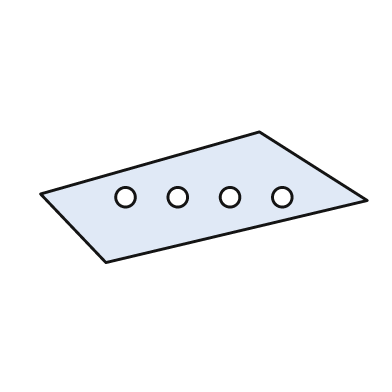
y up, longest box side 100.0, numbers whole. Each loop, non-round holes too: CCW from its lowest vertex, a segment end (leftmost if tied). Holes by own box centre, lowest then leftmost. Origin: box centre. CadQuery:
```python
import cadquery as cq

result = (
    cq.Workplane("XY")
    .moveTo(-30.0, -20.0)
    .lineTo(50.0, -1.0)
    .lineTo(17.0, 20.0)
    .lineTo(-50.0, 1.0)
    .close()
    .moveTo(-24.0, 0.0)
    .circle(3.0)
    .moveTo(-8.0, 0.0)
    .circle(3.0)
    .moveTo(8.0, 0.0)
    .circle(3.0)
    .moveTo(24.0, 0.0)
    .circle(3.0)
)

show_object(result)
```